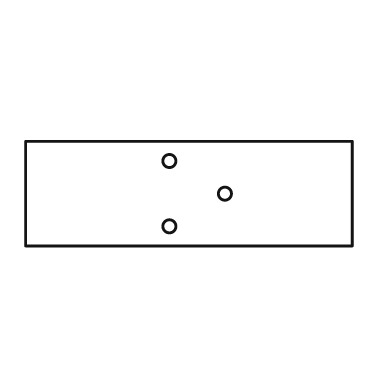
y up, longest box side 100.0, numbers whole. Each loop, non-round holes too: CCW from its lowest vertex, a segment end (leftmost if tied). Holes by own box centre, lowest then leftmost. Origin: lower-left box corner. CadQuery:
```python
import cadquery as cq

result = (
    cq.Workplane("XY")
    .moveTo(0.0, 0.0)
    .lineTo(100.0, 0.0)
    .lineTo(100.0, 32.0)
    .lineTo(0.0, 32.0)
    .close()
    .moveTo(44.0, 6.0)
    .circle(2.0)
    .moveTo(61.0, 16.0)
    .circle(2.0)
    .moveTo(44.0, 26.0)
    .circle(2.0)
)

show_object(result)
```